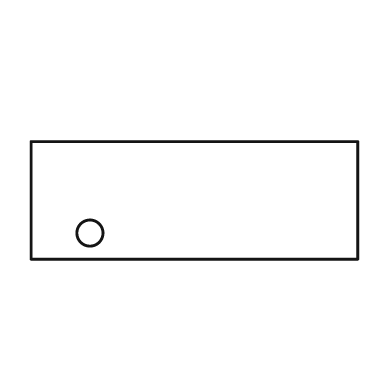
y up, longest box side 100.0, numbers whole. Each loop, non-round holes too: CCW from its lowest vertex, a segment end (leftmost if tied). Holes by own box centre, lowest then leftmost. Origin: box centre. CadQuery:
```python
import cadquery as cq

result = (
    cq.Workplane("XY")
    .moveTo(-50.0, -18.0)
    .lineTo(50.0, -18.0)
    .lineTo(50.0, 18.0)
    .lineTo(-50.0, 18.0)
    .close()
    .moveTo(-32.0, -10.0)
    .circle(4.0)
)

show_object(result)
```